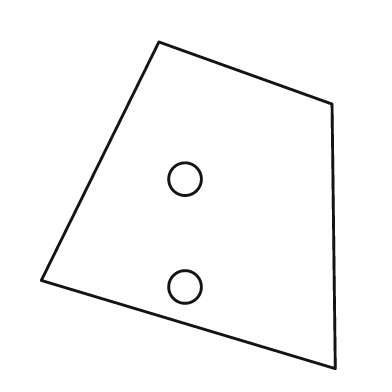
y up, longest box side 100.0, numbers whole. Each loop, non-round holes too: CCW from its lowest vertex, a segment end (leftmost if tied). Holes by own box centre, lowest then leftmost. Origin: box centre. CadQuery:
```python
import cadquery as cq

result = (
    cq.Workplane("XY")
    .moveTo(45.0, -50.0)
    .lineTo(44.0, 31.0)
    .lineTo(-9.0, 50.0)
    .lineTo(-45.0, -23.0)
    .close()
    .moveTo(-1.0, -25.0)
    .circle(5.0)
    .moveTo(-1.0, 8.0)
    .circle(5.0)
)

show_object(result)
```